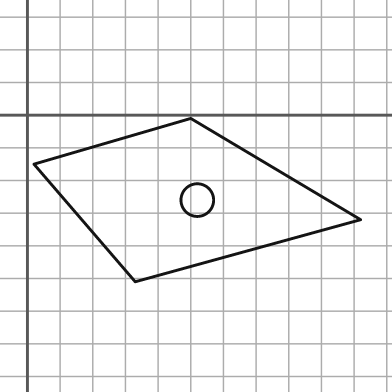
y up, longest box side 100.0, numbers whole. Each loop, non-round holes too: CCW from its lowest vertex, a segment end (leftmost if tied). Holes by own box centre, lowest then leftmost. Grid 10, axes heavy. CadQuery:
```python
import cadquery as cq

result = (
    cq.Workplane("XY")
    .moveTo(33.0, -51.0)
    .lineTo(102.0, -32.0)
    .lineTo(50.0, -1.0)
    .lineTo(2.0, -15.0)
    .close()
    .moveTo(52.0, -26.0)
    .circle(5.0)
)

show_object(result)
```